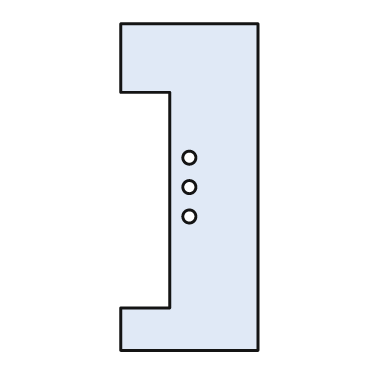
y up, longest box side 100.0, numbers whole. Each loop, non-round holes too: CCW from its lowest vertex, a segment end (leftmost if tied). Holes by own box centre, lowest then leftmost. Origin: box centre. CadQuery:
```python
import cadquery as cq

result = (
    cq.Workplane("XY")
    .moveTo(-21.0, -50.0)
    .lineTo(21.0, -50.0)
    .lineTo(21.0, 50.0)
    .lineTo(-21.0, 50.0)
    .lineTo(-21.0, 29.0)
    .lineTo(-6.0, 29.0)
    .lineTo(-6.0, -37.0)
    .lineTo(-21.0, -37.0)
    .close()
    .moveTo(0.0, -9.0)
    .circle(2.0)
    .moveTo(0.0, 0.0)
    .circle(2.0)
    .moveTo(0.0, 9.0)
    .circle(2.0)
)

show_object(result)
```